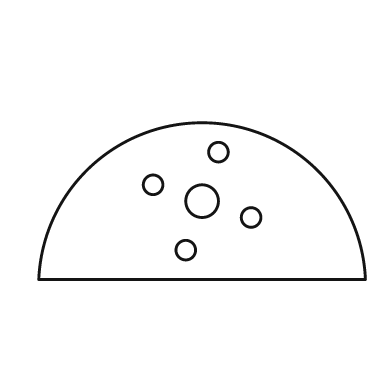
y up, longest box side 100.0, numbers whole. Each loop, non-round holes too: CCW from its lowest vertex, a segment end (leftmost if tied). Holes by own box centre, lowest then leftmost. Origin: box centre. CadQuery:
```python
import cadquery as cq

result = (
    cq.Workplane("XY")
    .moveTo(-50.0, -24.0)
    .lineTo(50.0, -24.0)
    .threePointArc((0.0, 24.0), (-50.0, -24.0))
    .close()
    .moveTo(-5.0, -15.0)
    .circle(3.0)
    .moveTo(15.0, -5.0)
    .circle(3.0)
    .moveTo(0.0, 0.0)
    .circle(5.0)
    .moveTo(-15.0, 5.0)
    .circle(3.0)
    .moveTo(5.0, 15.0)
    .circle(3.0)
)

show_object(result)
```